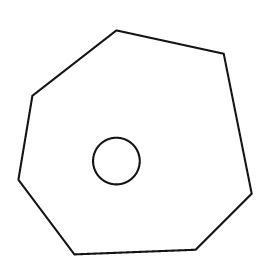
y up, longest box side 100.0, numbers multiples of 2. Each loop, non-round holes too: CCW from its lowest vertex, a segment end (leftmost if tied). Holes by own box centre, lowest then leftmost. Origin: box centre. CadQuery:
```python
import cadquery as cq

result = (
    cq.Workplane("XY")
    .moveTo(-26.0, -48.0)
    .lineTo(26.0, -46.0)
    .lineTo(50.0, -22.0)
    .lineTo(38.0, 38.0)
    .lineTo(-8.0, 48.0)
    .lineTo(-44.0, 20.0)
    .lineTo(-50.0, -16.0)
    .close()
    .moveTo(-8.0, -8.0)
    .circle(10.0)
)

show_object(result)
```